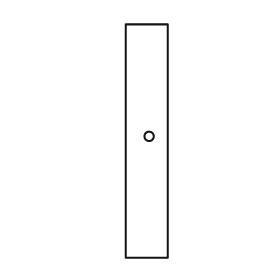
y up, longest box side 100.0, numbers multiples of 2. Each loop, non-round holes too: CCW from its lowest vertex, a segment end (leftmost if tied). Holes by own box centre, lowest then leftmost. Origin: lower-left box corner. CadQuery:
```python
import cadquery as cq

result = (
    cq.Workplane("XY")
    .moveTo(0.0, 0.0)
    .lineTo(18.0, 0.0)
    .lineTo(18.0, 100.0)
    .lineTo(0.0, 100.0)
    .close()
    .moveTo(10.0, 52.0)
    .circle(2.0)
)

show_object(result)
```